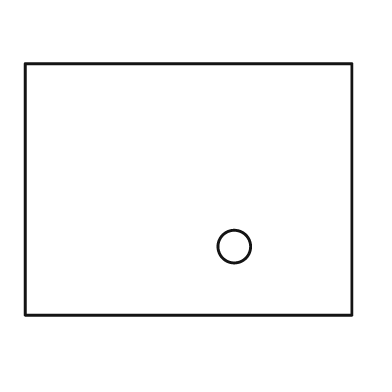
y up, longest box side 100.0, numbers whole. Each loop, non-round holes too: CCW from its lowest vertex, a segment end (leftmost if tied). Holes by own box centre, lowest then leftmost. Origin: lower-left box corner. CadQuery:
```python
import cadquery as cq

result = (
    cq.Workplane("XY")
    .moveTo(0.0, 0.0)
    .lineTo(100.0, 0.0)
    .lineTo(100.0, 77.0)
    .lineTo(0.0, 77.0)
    .close()
    .moveTo(64.0, 21.0)
    .circle(5.0)
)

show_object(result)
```